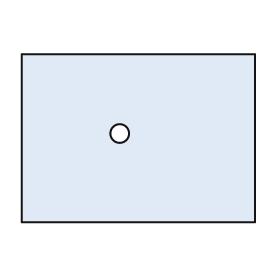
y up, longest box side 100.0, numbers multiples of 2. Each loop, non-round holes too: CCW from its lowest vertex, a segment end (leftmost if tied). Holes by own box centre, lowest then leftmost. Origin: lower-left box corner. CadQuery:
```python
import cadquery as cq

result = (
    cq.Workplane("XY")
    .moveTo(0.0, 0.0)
    .lineTo(100.0, 0.0)
    .lineTo(100.0, 72.0)
    .lineTo(0.0, 72.0)
    .close()
    .moveTo(42.0, 38.0)
    .circle(4.0)
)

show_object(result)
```